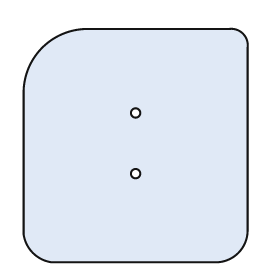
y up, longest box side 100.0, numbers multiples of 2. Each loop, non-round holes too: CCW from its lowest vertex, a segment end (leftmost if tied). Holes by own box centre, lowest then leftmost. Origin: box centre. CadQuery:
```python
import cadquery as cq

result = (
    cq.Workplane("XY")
    .moveTo(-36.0, -50.0)
    .lineTo(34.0, -50.0)
    .threePointArc((44.0, -46.0), (48.0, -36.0))
    .lineTo(48.0, 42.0)
    .threePointArc((46.0, 48.0), (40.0, 50.0))
    .lineTo(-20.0, 50.0)
    .threePointArc((-40.0, 42.0), (-48.0, 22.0))
    .lineTo(-48.0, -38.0)
    .threePointArc((-44.0, -46.0), (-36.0, -50.0))
    .close()
    .moveTo(0.0, -12.0)
    .circle(2.0)
    .moveTo(0.0, 14.0)
    .circle(2.0)
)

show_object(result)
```